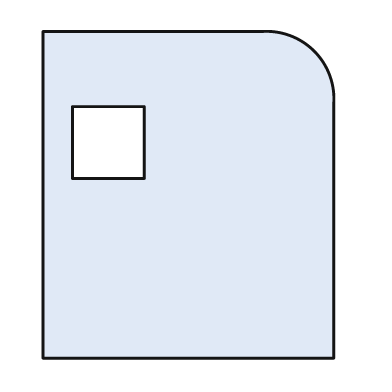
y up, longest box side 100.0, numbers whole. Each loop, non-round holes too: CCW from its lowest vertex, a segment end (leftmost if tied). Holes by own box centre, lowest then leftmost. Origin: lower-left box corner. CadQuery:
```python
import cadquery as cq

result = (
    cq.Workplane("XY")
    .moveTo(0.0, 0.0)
    .lineTo(89.0, 0.0)
    .lineTo(89.0, 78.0)
    .threePointArc((83.0, 94.0), (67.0, 100.0))
    .lineTo(0.0, 100.0)
    .close()
    .moveTo(9.0, 55.0)
    .lineTo(31.0, 55.0)
    .lineTo(31.0, 77.0)
    .lineTo(9.0, 77.0)
    .close()
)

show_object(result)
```